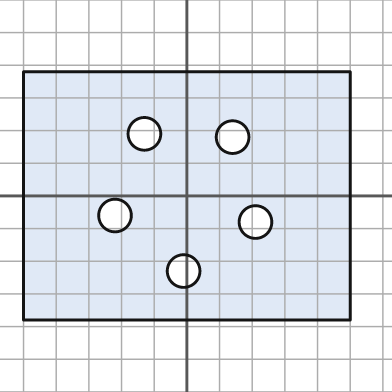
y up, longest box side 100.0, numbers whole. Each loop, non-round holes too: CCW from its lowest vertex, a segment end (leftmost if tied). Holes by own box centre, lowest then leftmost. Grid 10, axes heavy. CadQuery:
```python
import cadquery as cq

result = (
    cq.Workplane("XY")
    .moveTo(-50.0, -38.0)
    .lineTo(50.0, -38.0)
    .lineTo(50.0, 38.0)
    .lineTo(-50.0, 38.0)
    .close()
    .moveTo(-1.0, -23.0)
    .circle(5.0)
    .moveTo(21.0, -8.0)
    .circle(5.0)
    .moveTo(-22.0, -6.0)
    .circle(5.0)
    .moveTo(14.0, 18.0)
    .circle(5.0)
    .moveTo(-13.0, 19.0)
    .circle(5.0)
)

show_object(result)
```